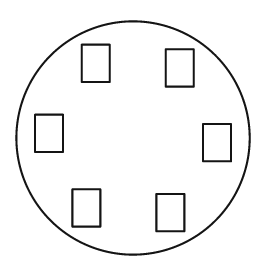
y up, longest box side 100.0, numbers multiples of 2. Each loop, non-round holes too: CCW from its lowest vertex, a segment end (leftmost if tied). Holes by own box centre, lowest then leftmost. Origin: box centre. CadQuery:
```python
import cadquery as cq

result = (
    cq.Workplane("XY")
    .moveTo(0.0, 0.0)
    .circle(50.0)
    .moveTo(10.0, -40.0)
    .lineTo(22.0, -40.0)
    .lineTo(22.0, -24.0)
    .lineTo(10.0, -24.0)
    .close()
    .moveTo(-26.0, -38.0)
    .lineTo(-14.0, -38.0)
    .lineTo(-14.0, -22.0)
    .lineTo(-26.0, -22.0)
    .close()
    .moveTo(30.0, -10.0)
    .lineTo(42.0, -10.0)
    .lineTo(42.0, 6.0)
    .lineTo(30.0, 6.0)
    .close()
    .moveTo(-42.0, -6.0)
    .lineTo(-30.0, -6.0)
    .lineTo(-30.0, 10.0)
    .lineTo(-42.0, 10.0)
    .close()
    .moveTo(14.0, 22.0)
    .lineTo(26.0, 22.0)
    .lineTo(26.0, 38.0)
    .lineTo(14.0, 38.0)
    .close()
    .moveTo(-22.0, 24.0)
    .lineTo(-10.0, 24.0)
    .lineTo(-10.0, 40.0)
    .lineTo(-22.0, 40.0)
    .close()
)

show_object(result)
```